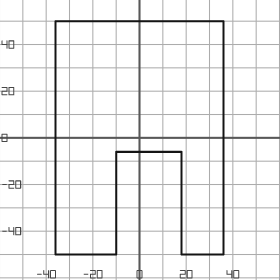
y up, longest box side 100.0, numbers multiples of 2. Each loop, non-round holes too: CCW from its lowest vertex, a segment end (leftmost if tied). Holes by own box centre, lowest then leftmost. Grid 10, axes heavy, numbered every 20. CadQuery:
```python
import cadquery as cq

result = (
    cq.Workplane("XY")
    .moveTo(-36.0, -50.0)
    .lineTo(-10.0, -50.0)
    .lineTo(-10.0, -6.0)
    .lineTo(18.0, -6.0)
    .lineTo(18.0, -50.0)
    .lineTo(36.0, -50.0)
    .lineTo(36.0, 50.0)
    .lineTo(-36.0, 50.0)
    .close()
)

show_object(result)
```